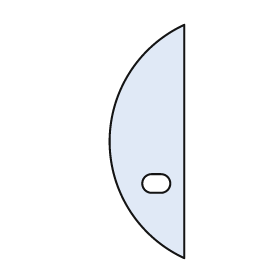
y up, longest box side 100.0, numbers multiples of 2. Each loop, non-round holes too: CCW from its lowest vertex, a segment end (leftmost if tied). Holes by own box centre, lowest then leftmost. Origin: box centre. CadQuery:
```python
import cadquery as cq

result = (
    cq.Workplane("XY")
    .moveTo(16.0, -50.0)
    .lineTo(16.0, 50.0)
    .threePointArc((-16.0, 0.0), (16.0, -50.0))
    .close()
    .moveTo(2.0, -22.0)
    .lineTo(6.0, -22.0)
    .threePointArc((10.0, -18.0), (6.0, -14.0))
    .lineTo(2.0, -14.0)
    .threePointArc((-2.0, -18.0), (2.0, -22.0))
    .close()
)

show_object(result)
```